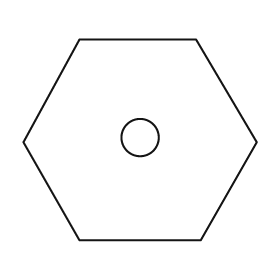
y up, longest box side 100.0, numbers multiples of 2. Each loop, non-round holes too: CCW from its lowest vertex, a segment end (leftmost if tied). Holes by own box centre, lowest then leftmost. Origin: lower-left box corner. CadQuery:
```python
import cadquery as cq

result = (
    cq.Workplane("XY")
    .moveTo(24.0, 0.0)
    .lineTo(76.0, 0.0)
    .lineTo(100.0, 42.0)
    .lineTo(74.0, 86.0)
    .lineTo(24.0, 86.0)
    .lineTo(0.0, 42.0)
    .close()
    .moveTo(50.0, 44.0)
    .circle(8.0)
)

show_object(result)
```